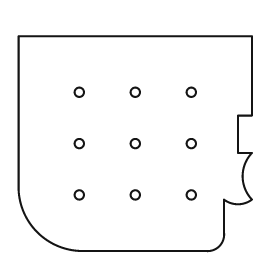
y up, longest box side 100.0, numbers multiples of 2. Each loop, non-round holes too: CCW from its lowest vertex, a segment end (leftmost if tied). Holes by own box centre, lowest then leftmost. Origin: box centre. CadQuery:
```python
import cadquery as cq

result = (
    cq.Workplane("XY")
    .moveTo(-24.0, -46.0)
    .lineTo(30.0, -46.0)
    .threePointArc((36.0, -44.0), (38.0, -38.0))
    .lineTo(38.0, -24.0)
    .threePointArc((44.0, -26.0), (50.0, -24.0))
    .threePointArc((46.0, -14.0), (50.0, -4.0))
    .lineTo(44.0, -4.0)
    .lineTo(44.0, 12.0)
    .lineTo(50.0, 12.0)
    .lineTo(50.0, 46.0)
    .lineTo(-50.0, 46.0)
    .lineTo(-50.0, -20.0)
    .threePointArc((-42.0, -38.0), (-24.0, -46.0))
    .close()
    .moveTo(-24.0, -22.0)
    .circle(2.0)
    .moveTo(0.0, -22.0)
    .circle(2.0)
    .moveTo(24.0, -22.0)
    .circle(2.0)
    .moveTo(-24.0, 0.0)
    .circle(2.0)
    .moveTo(0.0, 0.0)
    .circle(2.0)
    .moveTo(24.0, 0.0)
    .circle(2.0)
    .moveTo(-24.0, 22.0)
    .circle(2.0)
    .moveTo(0.0, 22.0)
    .circle(2.0)
    .moveTo(24.0, 22.0)
    .circle(2.0)
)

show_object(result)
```